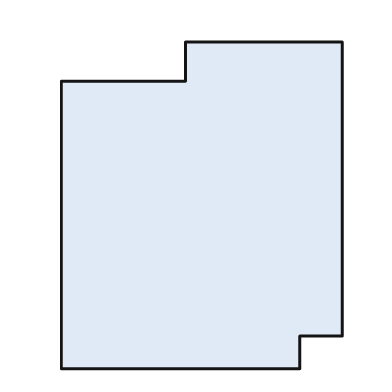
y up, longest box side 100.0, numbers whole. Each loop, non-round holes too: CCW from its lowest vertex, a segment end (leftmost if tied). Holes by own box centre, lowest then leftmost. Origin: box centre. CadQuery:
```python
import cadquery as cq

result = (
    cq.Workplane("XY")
    .moveTo(-43.0, -50.0)
    .lineTo(30.0, -50.0)
    .lineTo(30.0, -40.0)
    .lineTo(43.0, -40.0)
    .lineTo(43.0, 50.0)
    .lineTo(-5.0, 50.0)
    .lineTo(-5.0, 38.0)
    .lineTo(-43.0, 38.0)
    .close()
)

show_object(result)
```